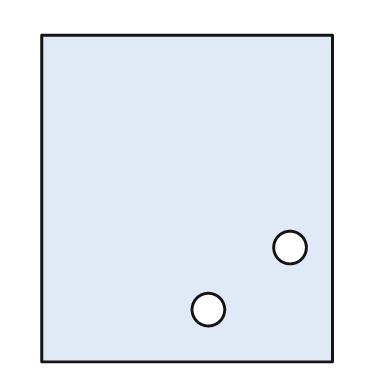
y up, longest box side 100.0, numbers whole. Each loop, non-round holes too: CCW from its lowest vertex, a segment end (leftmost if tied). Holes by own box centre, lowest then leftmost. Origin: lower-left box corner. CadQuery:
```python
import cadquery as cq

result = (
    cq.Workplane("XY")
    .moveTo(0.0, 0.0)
    .lineTo(89.0, 0.0)
    .lineTo(89.0, 100.0)
    .lineTo(0.0, 100.0)
    .close()
    .moveTo(51.0, 16.0)
    .circle(5.0)
    .moveTo(76.0, 35.0)
    .circle(5.0)
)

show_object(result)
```